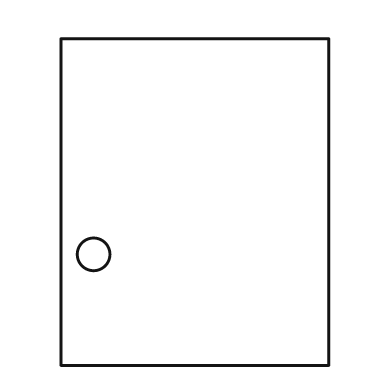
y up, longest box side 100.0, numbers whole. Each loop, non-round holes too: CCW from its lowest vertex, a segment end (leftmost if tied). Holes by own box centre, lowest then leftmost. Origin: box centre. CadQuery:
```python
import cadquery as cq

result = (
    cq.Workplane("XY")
    .moveTo(-41.0, -50.0)
    .lineTo(41.0, -50.0)
    .lineTo(41.0, 50.0)
    .lineTo(-41.0, 50.0)
    .close()
    .moveTo(-31.0, -16.0)
    .circle(5.0)
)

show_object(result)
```